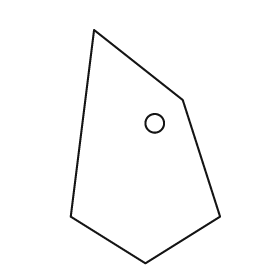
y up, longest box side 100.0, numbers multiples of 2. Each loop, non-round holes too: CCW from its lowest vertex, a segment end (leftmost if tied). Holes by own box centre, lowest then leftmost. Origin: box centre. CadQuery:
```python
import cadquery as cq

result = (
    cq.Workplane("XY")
    .moveTo(0.0, -50.0)
    .lineTo(32.0, -30.0)
    .lineTo(16.0, 20.0)
    .lineTo(-22.0, 50.0)
    .lineTo(-32.0, -30.0)
    .close()
    .moveTo(4.0, 10.0)
    .circle(4.0)
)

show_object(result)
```